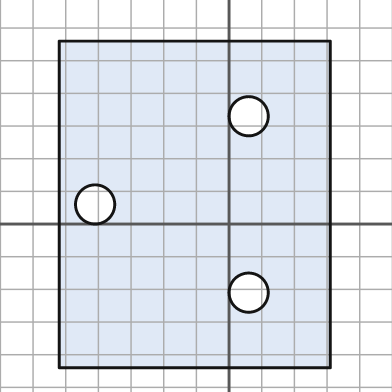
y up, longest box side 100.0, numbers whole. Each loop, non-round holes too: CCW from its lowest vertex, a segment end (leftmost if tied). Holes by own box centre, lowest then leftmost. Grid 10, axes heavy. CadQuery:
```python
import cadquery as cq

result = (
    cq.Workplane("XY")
    .moveTo(-52.0, -44.0)
    .lineTo(31.0, -44.0)
    .lineTo(31.0, 56.0)
    .lineTo(-52.0, 56.0)
    .close()
    .moveTo(6.0, -21.0)
    .circle(6.0)
    .moveTo(-41.0, 6.0)
    .circle(6.0)
    .moveTo(6.0, 33.0)
    .circle(6.0)
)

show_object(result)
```